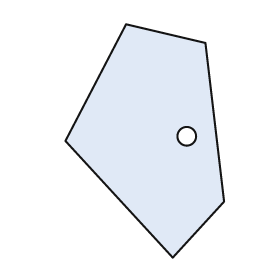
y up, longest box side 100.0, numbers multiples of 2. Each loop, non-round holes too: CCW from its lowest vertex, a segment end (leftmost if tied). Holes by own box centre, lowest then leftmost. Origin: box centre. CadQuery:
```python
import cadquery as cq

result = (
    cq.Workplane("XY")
    .moveTo(12.0, -50.0)
    .lineTo(34.0, -26.0)
    .lineTo(26.0, 42.0)
    .lineTo(-8.0, 50.0)
    .lineTo(-34.0, 0.0)
    .close()
    .moveTo(18.0, 2.0)
    .circle(4.0)
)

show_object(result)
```